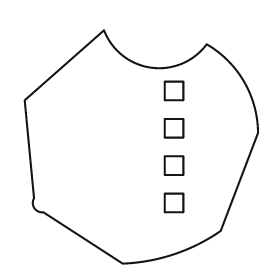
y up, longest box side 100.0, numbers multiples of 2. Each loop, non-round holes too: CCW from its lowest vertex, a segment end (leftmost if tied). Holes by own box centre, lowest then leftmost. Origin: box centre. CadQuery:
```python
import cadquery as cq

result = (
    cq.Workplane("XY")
    .moveTo(-8.0, -50.0)
    .threePointArc((14.0, -46.0), (34.0, -36.0))
    .lineTo(50.0, 6.0)
    .threePointArc((44.0, 28.0), (28.0, 44.0))
    .threePointArc((4.0, 34.0), (-16.0, 50.0))
    .lineTo(-50.0, 20.0)
    .lineTo(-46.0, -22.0)
    .threePointArc((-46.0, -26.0), (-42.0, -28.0))
    .close()
    .moveTo(10.0, -28.0)
    .lineTo(18.0, -28.0)
    .lineTo(18.0, -20.0)
    .lineTo(10.0, -20.0)
    .close()
    .moveTo(10.0, -12.0)
    .lineTo(18.0, -12.0)
    .lineTo(18.0, -4.0)
    .lineTo(10.0, -4.0)
    .close()
    .moveTo(10.0, 4.0)
    .lineTo(18.0, 4.0)
    .lineTo(18.0, 12.0)
    .lineTo(10.0, 12.0)
    .close()
    .moveTo(10.0, 20.0)
    .lineTo(18.0, 20.0)
    .lineTo(18.0, 28.0)
    .lineTo(10.0, 28.0)
    .close()
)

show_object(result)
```